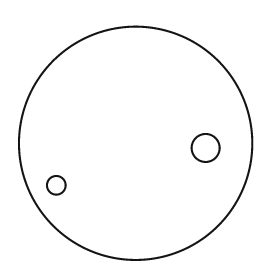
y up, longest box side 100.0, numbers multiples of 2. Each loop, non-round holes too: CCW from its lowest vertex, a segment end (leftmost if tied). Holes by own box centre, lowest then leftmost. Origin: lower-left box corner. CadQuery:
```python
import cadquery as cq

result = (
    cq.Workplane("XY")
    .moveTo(50.0, 50.0)
    .circle(50.0)
    .moveTo(16.0, 32.0)
    .circle(4.0)
    .moveTo(80.0, 48.0)
    .circle(6.0)
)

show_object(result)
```